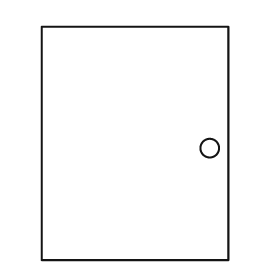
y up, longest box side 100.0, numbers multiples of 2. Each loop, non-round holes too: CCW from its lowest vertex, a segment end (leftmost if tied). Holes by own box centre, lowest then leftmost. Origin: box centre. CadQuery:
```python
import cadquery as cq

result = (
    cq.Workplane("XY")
    .moveTo(-40.0, -50.0)
    .lineTo(40.0, -50.0)
    .lineTo(40.0, 50.0)
    .lineTo(-40.0, 50.0)
    .close()
    .moveTo(32.0, -2.0)
    .circle(4.0)
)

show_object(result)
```